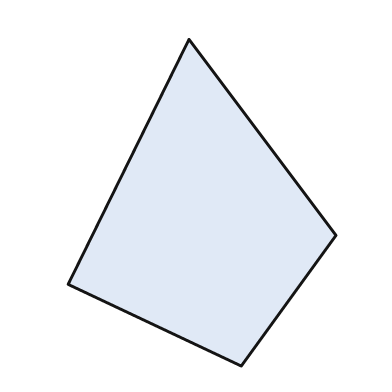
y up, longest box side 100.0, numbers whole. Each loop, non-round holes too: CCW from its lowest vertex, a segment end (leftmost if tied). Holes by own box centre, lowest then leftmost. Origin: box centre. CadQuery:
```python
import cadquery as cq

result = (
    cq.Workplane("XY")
    .moveTo(12.0, -50.0)
    .lineTo(41.0, -10.0)
    .lineTo(-4.0, 50.0)
    .lineTo(-41.0, -25.0)
    .close()
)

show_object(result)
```